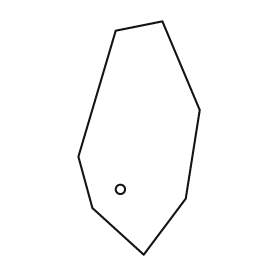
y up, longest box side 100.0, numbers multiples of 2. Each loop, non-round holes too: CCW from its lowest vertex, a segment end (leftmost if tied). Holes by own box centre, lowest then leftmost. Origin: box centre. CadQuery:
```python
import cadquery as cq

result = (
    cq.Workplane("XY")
    .moveTo(2.0, -50.0)
    .lineTo(20.0, -26.0)
    .lineTo(26.0, 12.0)
    .lineTo(10.0, 50.0)
    .lineTo(-10.0, 46.0)
    .lineTo(-26.0, -8.0)
    .lineTo(-20.0, -30.0)
    .close()
    .moveTo(-8.0, -22.0)
    .circle(2.0)
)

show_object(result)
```